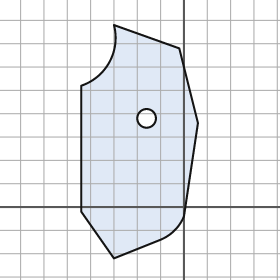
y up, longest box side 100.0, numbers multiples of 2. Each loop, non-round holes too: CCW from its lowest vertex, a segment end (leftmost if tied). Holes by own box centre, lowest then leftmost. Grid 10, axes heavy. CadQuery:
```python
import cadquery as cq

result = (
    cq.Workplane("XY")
    .moveTo(-30.0, -22.0)
    .lineTo(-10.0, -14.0)
    .threePointArc((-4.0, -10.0), (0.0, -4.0))
    .lineTo(6.0, 36.0)
    .lineTo(-2.0, 68.0)
    .lineTo(-30.0, 78.0)
    .threePointArc((-32.0, 62.0), (-44.0, 52.0))
    .lineTo(-44.0, -2.0)
    .close()
    .moveTo(-16.0, 38.0)
    .circle(4.0)
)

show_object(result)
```